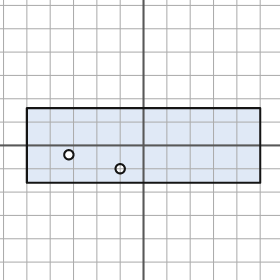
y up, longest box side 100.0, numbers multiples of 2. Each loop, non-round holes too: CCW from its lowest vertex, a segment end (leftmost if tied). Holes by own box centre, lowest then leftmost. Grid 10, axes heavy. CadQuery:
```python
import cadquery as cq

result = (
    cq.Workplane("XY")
    .moveTo(-50.0, -16.0)
    .lineTo(50.0, -16.0)
    .lineTo(50.0, 16.0)
    .lineTo(-50.0, 16.0)
    .close()
    .moveTo(-10.0, -10.0)
    .circle(2.0)
    .moveTo(-32.0, -4.0)
    .circle(2.0)
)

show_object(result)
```